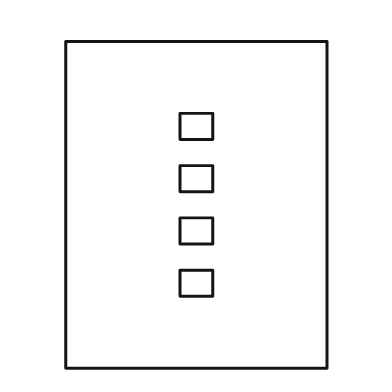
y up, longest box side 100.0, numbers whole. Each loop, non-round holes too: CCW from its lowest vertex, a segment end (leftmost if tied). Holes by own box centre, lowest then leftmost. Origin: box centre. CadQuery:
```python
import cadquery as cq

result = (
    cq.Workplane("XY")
    .moveTo(-40.0, -50.0)
    .lineTo(40.0, -50.0)
    .lineTo(40.0, 50.0)
    .lineTo(-40.0, 50.0)
    .close()
    .moveTo(-5.0, -28.0)
    .lineTo(5.0, -28.0)
    .lineTo(5.0, -20.0)
    .lineTo(-5.0, -20.0)
    .close()
    .moveTo(-5.0, -12.0)
    .lineTo(5.0, -12.0)
    .lineTo(5.0, -4.0)
    .lineTo(-5.0, -4.0)
    .close()
    .moveTo(-5.0, 4.0)
    .lineTo(5.0, 4.0)
    .lineTo(5.0, 12.0)
    .lineTo(-5.0, 12.0)
    .close()
    .moveTo(-5.0, 20.0)
    .lineTo(5.0, 20.0)
    .lineTo(5.0, 28.0)
    .lineTo(-5.0, 28.0)
    .close()
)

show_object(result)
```